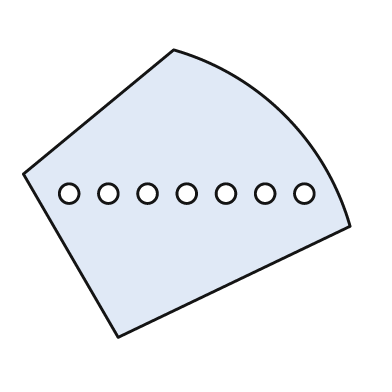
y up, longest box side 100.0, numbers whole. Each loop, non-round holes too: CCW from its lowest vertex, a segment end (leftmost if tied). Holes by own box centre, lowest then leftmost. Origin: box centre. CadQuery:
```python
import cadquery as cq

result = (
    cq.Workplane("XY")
    .moveTo(-21.0, -44.0)
    .lineTo(50.0, -10.0)
    .threePointArc((30.0, 24.0), (-4.0, 44.0))
    .lineTo(-50.0, 6.0)
    .close()
    .moveTo(-36.0, 0.0)
    .circle(3.0)
    .moveTo(-24.0, 0.0)
    .circle(3.0)
    .moveTo(-12.0, 0.0)
    .circle(3.0)
    .moveTo(0.0, 0.0)
    .circle(3.0)
    .moveTo(12.0, 0.0)
    .circle(3.0)
    .moveTo(24.0, 0.0)
    .circle(3.0)
    .moveTo(36.0, 0.0)
    .circle(3.0)
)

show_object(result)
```